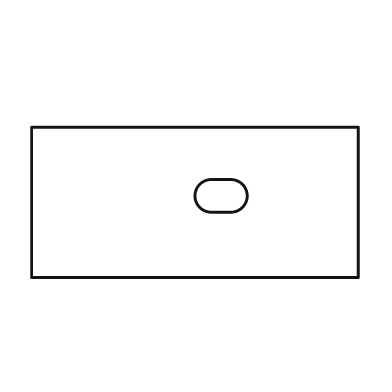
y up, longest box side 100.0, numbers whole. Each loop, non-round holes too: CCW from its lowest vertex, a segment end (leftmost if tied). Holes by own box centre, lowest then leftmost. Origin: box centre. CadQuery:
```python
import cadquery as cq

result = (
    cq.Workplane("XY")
    .moveTo(-50.0, -23.0)
    .lineTo(50.0, -23.0)
    .lineTo(50.0, 23.0)
    .lineTo(-50.0, 23.0)
    .close()
    .moveTo(5.0, -3.0)
    .lineTo(11.0, -3.0)
    .threePointArc((16.0, 2.0), (11.0, 7.0))
    .lineTo(5.0, 7.0)
    .threePointArc((0.0, 2.0), (5.0, -3.0))
    .close()
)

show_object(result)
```